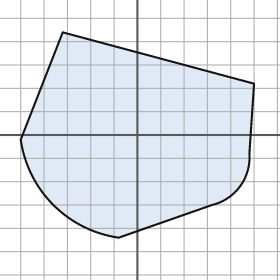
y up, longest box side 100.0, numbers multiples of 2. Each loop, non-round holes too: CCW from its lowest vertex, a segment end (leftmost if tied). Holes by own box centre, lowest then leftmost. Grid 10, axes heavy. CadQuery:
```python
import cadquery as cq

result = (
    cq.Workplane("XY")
    .moveTo(-8.0, -44.0)
    .lineTo(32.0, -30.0)
    .threePointArc((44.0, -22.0), (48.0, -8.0))
    .lineTo(50.0, 22.0)
    .lineTo(-32.0, 44.0)
    .lineTo(-50.0, -2.0)
    .threePointArc((-36.0, -30.0), (-8.0, -44.0))
    .close()
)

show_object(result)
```